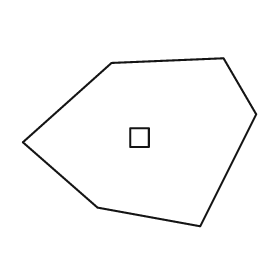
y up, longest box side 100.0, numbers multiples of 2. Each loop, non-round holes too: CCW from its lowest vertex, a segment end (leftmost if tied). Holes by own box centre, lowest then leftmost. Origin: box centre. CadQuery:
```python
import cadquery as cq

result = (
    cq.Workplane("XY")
    .moveTo(26.0, -36.0)
    .lineTo(50.0, 12.0)
    .lineTo(36.0, 36.0)
    .lineTo(-12.0, 34.0)
    .lineTo(-50.0, 0.0)
    .lineTo(-18.0, -28.0)
    .close()
    .moveTo(-4.0, -2.0)
    .lineTo(4.0, -2.0)
    .lineTo(4.0, 6.0)
    .lineTo(-4.0, 6.0)
    .close()
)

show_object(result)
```